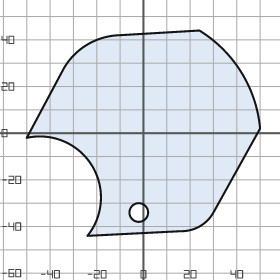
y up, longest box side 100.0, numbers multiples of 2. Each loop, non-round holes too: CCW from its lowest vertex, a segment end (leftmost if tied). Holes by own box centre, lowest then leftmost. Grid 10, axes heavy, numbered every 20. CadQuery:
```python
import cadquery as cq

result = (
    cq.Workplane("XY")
    .moveTo(-24.0, -44.0)
    .lineTo(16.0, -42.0)
    .threePointArc((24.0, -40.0), (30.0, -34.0))
    .lineTo(50.0, 2.0)
    .threePointArc((42.0, 26.0), (24.0, 44.0))
    .lineTo(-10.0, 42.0)
    .threePointArc((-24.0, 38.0), (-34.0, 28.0))
    .lineTo(-50.0, -2.0)
    .threePointArc((-22.0, -14.0), (-24.0, -44.0))
    .close()
    .moveTo(-2.0, -34.0)
    .circle(4.0)
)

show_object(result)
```